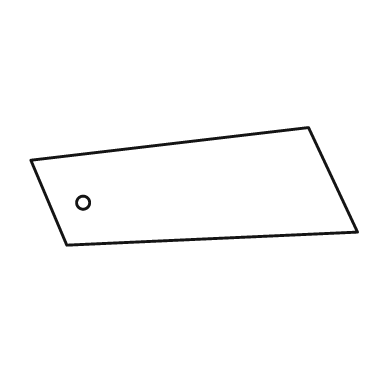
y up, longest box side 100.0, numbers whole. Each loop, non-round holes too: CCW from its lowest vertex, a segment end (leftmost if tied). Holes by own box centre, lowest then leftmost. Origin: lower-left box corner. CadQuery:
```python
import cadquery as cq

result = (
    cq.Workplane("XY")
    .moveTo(11.0, 0.0)
    .lineTo(100.0, 4.0)
    .lineTo(85.0, 36.0)
    .lineTo(0.0, 26.0)
    .close()
    .moveTo(16.0, 13.0)
    .circle(2.0)
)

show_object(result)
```